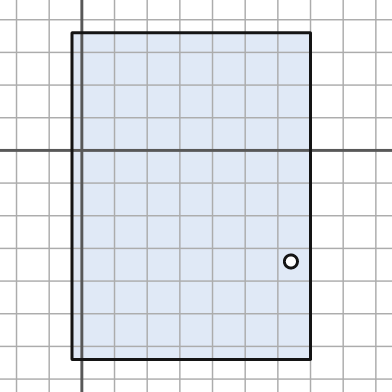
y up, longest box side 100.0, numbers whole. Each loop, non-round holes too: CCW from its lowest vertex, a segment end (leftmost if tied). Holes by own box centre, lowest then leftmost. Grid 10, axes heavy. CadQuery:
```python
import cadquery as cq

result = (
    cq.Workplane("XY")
    .moveTo(-3.0, -64.0)
    .lineTo(70.0, -64.0)
    .lineTo(70.0, 36.0)
    .lineTo(-3.0, 36.0)
    .close()
    .moveTo(64.0, -34.0)
    .circle(2.0)
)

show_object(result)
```